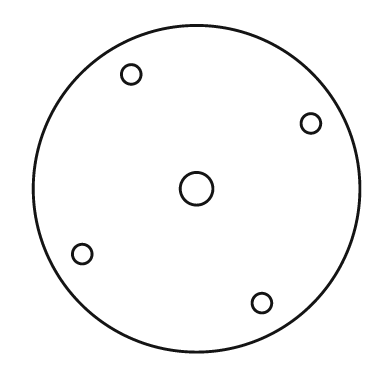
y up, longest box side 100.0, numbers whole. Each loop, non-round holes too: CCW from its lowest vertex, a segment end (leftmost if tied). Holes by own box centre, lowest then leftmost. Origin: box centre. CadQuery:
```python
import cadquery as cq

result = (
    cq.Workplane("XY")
    .moveTo(0.0, 0.0)
    .circle(50.0)
    .moveTo(20.0, -35.0)
    .circle(3.0)
    .moveTo(-35.0, -20.0)
    .circle(3.0)
    .moveTo(0.0, 0.0)
    .circle(5.0)
    .moveTo(35.0, 20.0)
    .circle(3.0)
    .moveTo(-20.0, 35.0)
    .circle(3.0)
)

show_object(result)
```